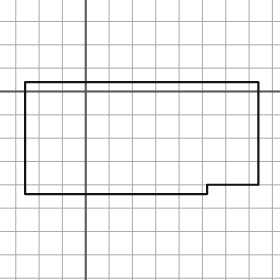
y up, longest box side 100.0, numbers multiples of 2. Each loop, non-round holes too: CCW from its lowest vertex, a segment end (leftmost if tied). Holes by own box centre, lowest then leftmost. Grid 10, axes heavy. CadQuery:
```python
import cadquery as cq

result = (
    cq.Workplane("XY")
    .moveTo(-26.0, -44.0)
    .lineTo(52.0, -44.0)
    .lineTo(52.0, -40.0)
    .lineTo(74.0, -40.0)
    .lineTo(74.0, 4.0)
    .lineTo(-26.0, 4.0)
    .close()
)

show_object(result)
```